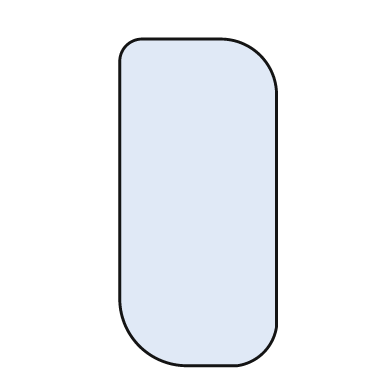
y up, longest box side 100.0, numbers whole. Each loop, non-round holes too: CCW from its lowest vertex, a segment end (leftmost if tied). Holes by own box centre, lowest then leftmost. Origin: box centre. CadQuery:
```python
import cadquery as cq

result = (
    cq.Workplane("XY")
    .moveTo(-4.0, -50.0)
    .lineTo(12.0, -50.0)
    .threePointArc((20.0, -46.0), (24.0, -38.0))
    .lineTo(24.0, 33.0)
    .threePointArc((19.0, 45.0), (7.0, 50.0))
    .lineTo(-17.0, 50.0)
    .threePointArc((-22.0, 48.0), (-24.0, 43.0))
    .lineTo(-24.0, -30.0)
    .threePointArc((-18.0, -44.0), (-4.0, -50.0))
    .close()
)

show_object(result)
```